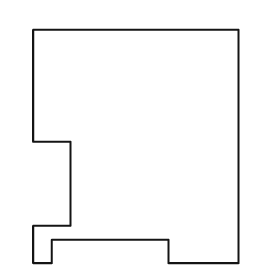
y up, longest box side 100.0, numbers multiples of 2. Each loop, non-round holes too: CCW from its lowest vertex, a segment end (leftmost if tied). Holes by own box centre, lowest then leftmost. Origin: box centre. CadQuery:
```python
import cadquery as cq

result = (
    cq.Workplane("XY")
    .moveTo(-44.0, -50.0)
    .lineTo(-36.0, -50.0)
    .lineTo(-36.0, -40.0)
    .lineTo(14.0, -40.0)
    .lineTo(14.0, -50.0)
    .lineTo(44.0, -50.0)
    .lineTo(44.0, 50.0)
    .lineTo(-44.0, 50.0)
    .lineTo(-44.0, 2.0)
    .lineTo(-28.0, 2.0)
    .lineTo(-28.0, -34.0)
    .lineTo(-44.0, -34.0)
    .close()
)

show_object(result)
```